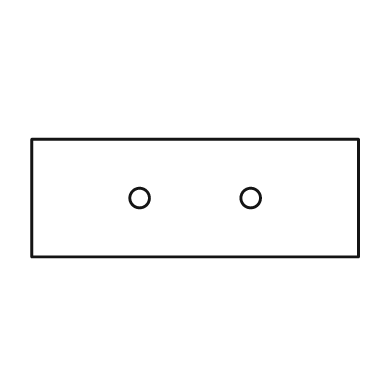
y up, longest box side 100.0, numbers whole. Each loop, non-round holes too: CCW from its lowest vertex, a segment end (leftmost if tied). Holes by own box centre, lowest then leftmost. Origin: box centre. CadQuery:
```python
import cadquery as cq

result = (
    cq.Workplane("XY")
    .moveTo(-50.0, -18.0)
    .lineTo(50.0, -18.0)
    .lineTo(50.0, 18.0)
    .lineTo(-50.0, 18.0)
    .close()
    .moveTo(-17.0, 0.0)
    .circle(3.0)
    .moveTo(17.0, 0.0)
    .circle(3.0)
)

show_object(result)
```